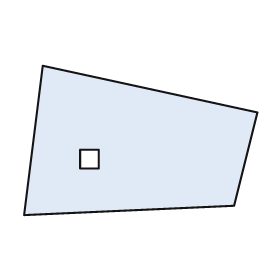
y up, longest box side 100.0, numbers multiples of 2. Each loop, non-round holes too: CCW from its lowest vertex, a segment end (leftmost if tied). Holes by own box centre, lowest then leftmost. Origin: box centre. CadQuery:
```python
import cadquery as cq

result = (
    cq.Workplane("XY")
    .moveTo(-50.0, -32.0)
    .lineTo(40.0, -28.0)
    .lineTo(50.0, 12.0)
    .lineTo(-42.0, 32.0)
    .close()
    .moveTo(-26.0, -12.0)
    .lineTo(-18.0, -12.0)
    .lineTo(-18.0, -4.0)
    .lineTo(-26.0, -4.0)
    .close()
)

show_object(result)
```